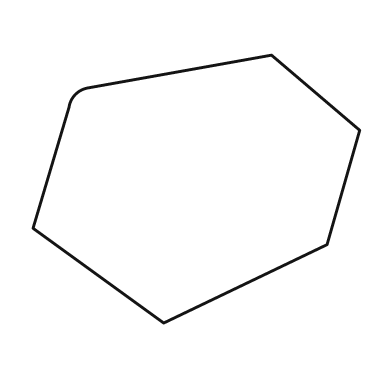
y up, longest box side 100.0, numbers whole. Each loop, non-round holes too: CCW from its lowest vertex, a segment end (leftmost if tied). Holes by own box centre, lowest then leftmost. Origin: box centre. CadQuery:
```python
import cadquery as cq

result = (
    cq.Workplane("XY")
    .moveTo(-10.0, -41.0)
    .lineTo(40.0, -17.0)
    .lineTo(50.0, 18.0)
    .lineTo(23.0, 41.0)
    .lineTo(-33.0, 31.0)
    .threePointArc((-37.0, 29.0), (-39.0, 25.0))
    .lineTo(-50.0, -12.0)
    .close()
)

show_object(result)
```